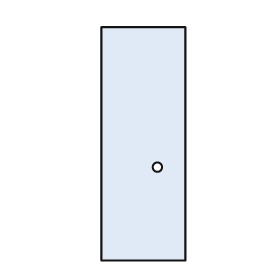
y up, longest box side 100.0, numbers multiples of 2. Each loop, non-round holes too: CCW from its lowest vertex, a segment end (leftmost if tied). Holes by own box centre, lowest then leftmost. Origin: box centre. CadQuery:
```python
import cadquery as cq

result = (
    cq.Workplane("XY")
    .moveTo(-18.0, -50.0)
    .lineTo(18.0, -50.0)
    .lineTo(18.0, 50.0)
    .lineTo(-18.0, 50.0)
    .close()
    .moveTo(6.0, -10.0)
    .circle(2.0)
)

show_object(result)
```